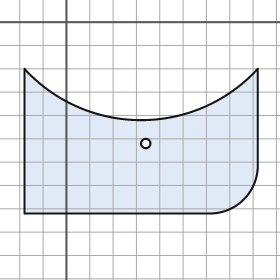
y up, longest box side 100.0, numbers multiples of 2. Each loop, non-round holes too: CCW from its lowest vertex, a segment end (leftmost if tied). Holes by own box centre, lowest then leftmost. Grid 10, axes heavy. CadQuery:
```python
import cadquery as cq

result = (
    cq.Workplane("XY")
    .moveTo(-18.0, -82.0)
    .lineTo(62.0, -82.0)
    .threePointArc((76.0, -76.0), (82.0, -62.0))
    .lineTo(82.0, -20.0)
    .threePointArc((32.0, -42.0), (-18.0, -20.0))
    .close()
    .moveTo(34.0, -52.0)
    .circle(2.0)
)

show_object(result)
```